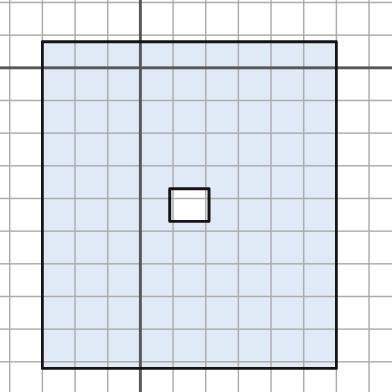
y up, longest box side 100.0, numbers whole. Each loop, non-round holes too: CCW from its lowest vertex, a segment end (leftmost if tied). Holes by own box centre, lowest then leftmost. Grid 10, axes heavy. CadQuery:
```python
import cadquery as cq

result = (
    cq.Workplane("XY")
    .moveTo(-30.0, -92.0)
    .lineTo(60.0, -92.0)
    .lineTo(60.0, 8.0)
    .lineTo(-30.0, 8.0)
    .close()
    .moveTo(9.0, -47.0)
    .lineTo(21.0, -47.0)
    .lineTo(21.0, -37.0)
    .lineTo(9.0, -37.0)
    .close()
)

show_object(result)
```